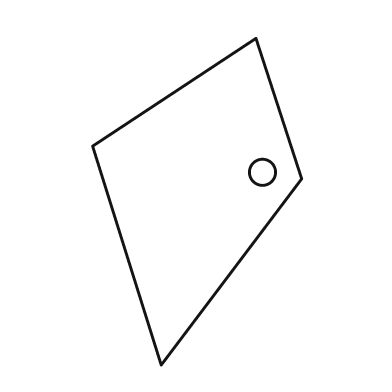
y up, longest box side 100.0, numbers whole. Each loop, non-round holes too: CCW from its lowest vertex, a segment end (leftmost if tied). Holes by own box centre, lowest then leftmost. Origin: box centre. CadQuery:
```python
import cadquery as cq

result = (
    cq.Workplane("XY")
    .moveTo(-11.0, -50.0)
    .lineTo(32.0, 7.0)
    .lineTo(18.0, 50.0)
    .lineTo(-32.0, 17.0)
    .close()
    .moveTo(20.0, 9.0)
    .circle(4.0)
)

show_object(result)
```